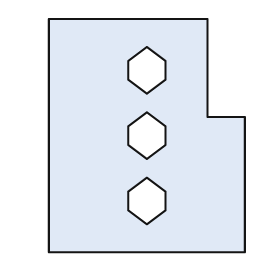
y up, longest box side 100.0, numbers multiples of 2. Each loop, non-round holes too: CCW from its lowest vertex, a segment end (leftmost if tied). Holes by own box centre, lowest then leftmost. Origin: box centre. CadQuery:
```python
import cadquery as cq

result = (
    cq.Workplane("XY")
    .moveTo(-42.0, -50.0)
    .lineTo(42.0, -50.0)
    .lineTo(42.0, 8.0)
    .lineTo(26.0, 8.0)
    .lineTo(26.0, 50.0)
    .lineTo(-42.0, 50.0)
    .close()
    .moveTo(0.0, -38.0)
    .lineTo(8.0, -32.0)
    .lineTo(8.0, -24.0)
    .lineTo(0.0, -18.0)
    .lineTo(-8.0, -24.0)
    .lineTo(-8.0, -32.0)
    .close()
    .moveTo(0.0, -10.0)
    .lineTo(8.0, -4.0)
    .lineTo(8.0, 4.0)
    .lineTo(0.0, 10.0)
    .lineTo(-8.0, 4.0)
    .lineTo(-8.0, -4.0)
    .close()
    .moveTo(0.0, 18.0)
    .lineTo(8.0, 24.0)
    .lineTo(8.0, 32.0)
    .lineTo(0.0, 38.0)
    .lineTo(-8.0, 32.0)
    .lineTo(-8.0, 24.0)
    .close()
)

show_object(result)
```